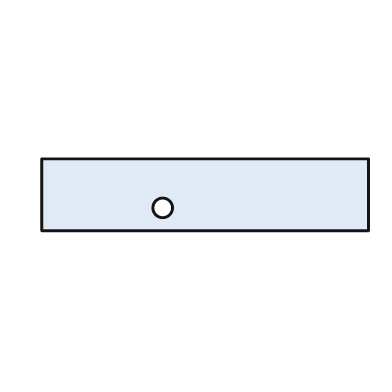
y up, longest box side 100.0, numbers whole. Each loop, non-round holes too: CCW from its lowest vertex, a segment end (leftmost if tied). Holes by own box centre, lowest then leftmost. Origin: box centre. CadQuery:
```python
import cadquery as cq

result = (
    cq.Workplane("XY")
    .moveTo(-50.0, -11.0)
    .lineTo(50.0, -11.0)
    .lineTo(50.0, 11.0)
    .lineTo(-50.0, 11.0)
    .close()
    .moveTo(-13.0, -4.0)
    .circle(3.0)
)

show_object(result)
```